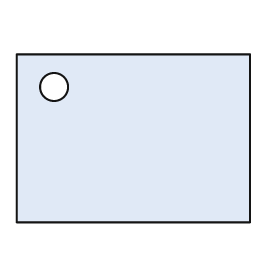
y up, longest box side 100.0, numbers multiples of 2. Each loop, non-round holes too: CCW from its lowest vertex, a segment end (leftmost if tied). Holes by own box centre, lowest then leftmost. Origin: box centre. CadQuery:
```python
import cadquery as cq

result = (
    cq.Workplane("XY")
    .moveTo(-50.0, -36.0)
    .lineTo(50.0, -36.0)
    .lineTo(50.0, 36.0)
    .lineTo(-50.0, 36.0)
    .close()
    .moveTo(-34.0, 22.0)
    .circle(6.0)
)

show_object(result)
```